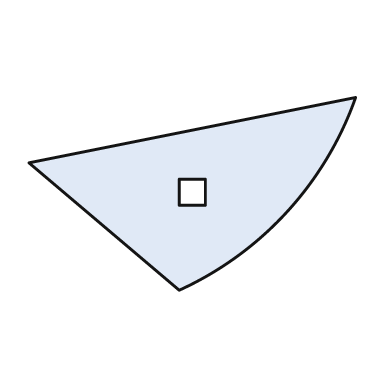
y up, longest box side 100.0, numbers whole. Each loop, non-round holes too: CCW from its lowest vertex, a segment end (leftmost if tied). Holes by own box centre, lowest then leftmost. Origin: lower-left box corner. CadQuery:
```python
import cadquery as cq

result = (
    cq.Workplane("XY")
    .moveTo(46.0, 0.0)
    .threePointArc((79.0, 24.0), (100.0, 59.0))
    .lineTo(0.0, 39.0)
    .close()
    .moveTo(46.0, 26.0)
    .lineTo(54.0, 26.0)
    .lineTo(54.0, 34.0)
    .lineTo(46.0, 34.0)
    .close()
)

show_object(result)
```